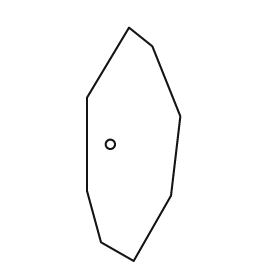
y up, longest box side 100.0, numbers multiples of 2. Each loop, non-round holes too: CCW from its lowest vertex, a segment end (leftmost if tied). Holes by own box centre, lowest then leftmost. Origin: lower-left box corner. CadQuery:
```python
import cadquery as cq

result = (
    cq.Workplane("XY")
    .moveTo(20.0, 0.0)
    .lineTo(36.0, 28.0)
    .lineTo(40.0, 62.0)
    .lineTo(28.0, 92.0)
    .lineTo(18.0, 100.0)
    .lineTo(0.0, 70.0)
    .lineTo(0.0, 30.0)
    .lineTo(6.0, 8.0)
    .close()
    .moveTo(10.0, 50.0)
    .circle(2.0)
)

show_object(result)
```